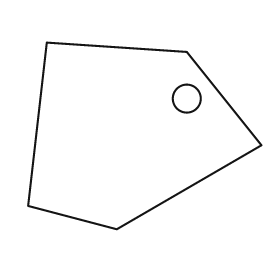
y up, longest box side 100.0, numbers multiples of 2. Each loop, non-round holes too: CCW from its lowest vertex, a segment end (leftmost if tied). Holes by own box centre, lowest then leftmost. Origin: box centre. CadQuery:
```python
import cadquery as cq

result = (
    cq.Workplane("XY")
    .moveTo(-12.0, -40.0)
    .lineTo(50.0, -4.0)
    .lineTo(18.0, 36.0)
    .lineTo(-42.0, 40.0)
    .lineTo(-50.0, -30.0)
    .close()
    .moveTo(18.0, 16.0)
    .circle(6.0)
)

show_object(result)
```